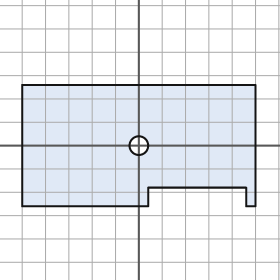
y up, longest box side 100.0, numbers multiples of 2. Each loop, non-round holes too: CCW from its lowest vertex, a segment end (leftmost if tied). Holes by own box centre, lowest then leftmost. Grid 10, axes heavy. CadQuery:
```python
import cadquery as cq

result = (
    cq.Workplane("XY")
    .moveTo(-50.0, -26.0)
    .lineTo(4.0, -26.0)
    .lineTo(4.0, -18.0)
    .lineTo(46.0, -18.0)
    .lineTo(46.0, -26.0)
    .lineTo(50.0, -26.0)
    .lineTo(50.0, 26.0)
    .lineTo(-50.0, 26.0)
    .close()
    .moveTo(0.0, 0.0)
    .circle(4.0)
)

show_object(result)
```